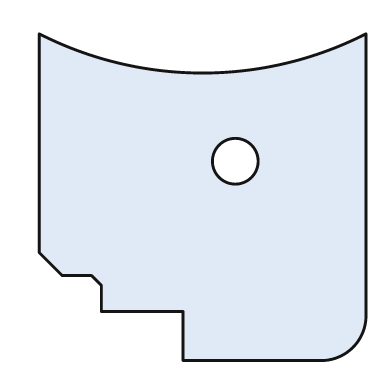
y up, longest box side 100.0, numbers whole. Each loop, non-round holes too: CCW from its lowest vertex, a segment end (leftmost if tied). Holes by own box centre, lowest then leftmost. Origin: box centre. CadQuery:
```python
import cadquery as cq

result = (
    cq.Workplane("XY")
    .moveTo(-6.0, -50.0)
    .lineTo(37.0, -50.0)
    .threePointArc((46.0, -46.0), (50.0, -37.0))
    .lineTo(50.0, 50.0)
    .threePointArc((0.0, 38.0), (-50.0, 50.0))
    .lineTo(-50.0, -17.0)
    .lineTo(-43.0, -24.0)
    .lineTo(-34.0, -24.0)
    .lineTo(-31.0, -27.0)
    .lineTo(-31.0, -35.0)
    .lineTo(-6.0, -35.0)
    .close()
    .moveTo(10.0, 11.0)
    .circle(7.0)
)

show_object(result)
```